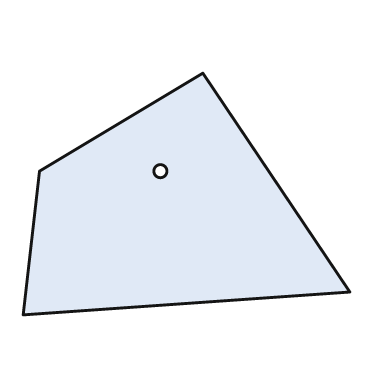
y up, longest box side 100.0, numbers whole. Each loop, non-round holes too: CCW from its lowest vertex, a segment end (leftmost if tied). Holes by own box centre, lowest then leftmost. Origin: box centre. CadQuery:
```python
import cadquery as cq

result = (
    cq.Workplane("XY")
    .moveTo(-50.0, -37.0)
    .lineTo(50.0, -30.0)
    .lineTo(5.0, 37.0)
    .lineTo(-45.0, 7.0)
    .close()
    .moveTo(-8.0, 7.0)
    .circle(2.0)
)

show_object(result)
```